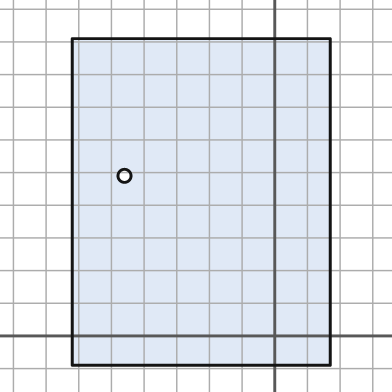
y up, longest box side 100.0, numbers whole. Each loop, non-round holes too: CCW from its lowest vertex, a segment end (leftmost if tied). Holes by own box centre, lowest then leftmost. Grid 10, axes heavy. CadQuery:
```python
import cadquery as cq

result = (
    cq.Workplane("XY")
    .moveTo(-62.0, -9.0)
    .lineTo(17.0, -9.0)
    .lineTo(17.0, 91.0)
    .lineTo(-62.0, 91.0)
    .close()
    .moveTo(-46.0, 49.0)
    .circle(2.0)
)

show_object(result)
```